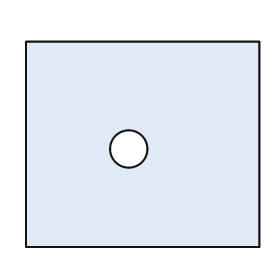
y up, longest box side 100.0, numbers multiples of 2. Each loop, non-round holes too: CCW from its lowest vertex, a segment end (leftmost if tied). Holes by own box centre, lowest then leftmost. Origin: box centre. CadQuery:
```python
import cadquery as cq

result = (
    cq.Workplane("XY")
    .moveTo(-50.0, -44.0)
    .lineTo(50.0, -44.0)
    .lineTo(50.0, 44.0)
    .lineTo(-50.0, 44.0)
    .close()
    .moveTo(-6.0, -2.0)
    .circle(8.0)
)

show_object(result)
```